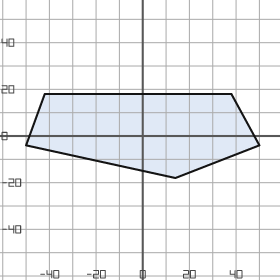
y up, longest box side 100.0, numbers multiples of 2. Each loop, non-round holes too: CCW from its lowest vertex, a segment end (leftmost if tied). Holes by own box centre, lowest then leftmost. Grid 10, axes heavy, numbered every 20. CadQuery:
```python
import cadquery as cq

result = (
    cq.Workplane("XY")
    .moveTo(14.0, -18.0)
    .lineTo(50.0, -4.0)
    .lineTo(38.0, 18.0)
    .lineTo(-42.0, 18.0)
    .lineTo(-50.0, -4.0)
    .close()
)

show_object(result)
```